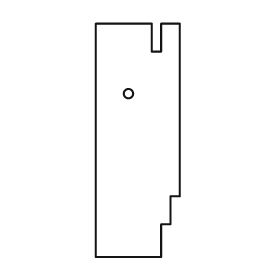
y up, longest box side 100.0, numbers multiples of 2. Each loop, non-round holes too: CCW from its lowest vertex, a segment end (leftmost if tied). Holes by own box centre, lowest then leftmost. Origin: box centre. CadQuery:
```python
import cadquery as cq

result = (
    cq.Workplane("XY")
    .moveTo(-18.0, -50.0)
    .lineTo(10.0, -50.0)
    .lineTo(10.0, -36.0)
    .lineTo(14.0, -36.0)
    .lineTo(14.0, -24.0)
    .lineTo(18.0, -24.0)
    .lineTo(18.0, 50.0)
    .lineTo(10.0, 50.0)
    .lineTo(10.0, 38.0)
    .lineTo(6.0, 38.0)
    .lineTo(6.0, 50.0)
    .lineTo(-18.0, 50.0)
    .close()
    .moveTo(-4.0, 20.0)
    .circle(2.0)
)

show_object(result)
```